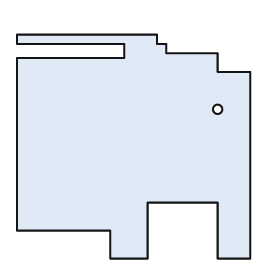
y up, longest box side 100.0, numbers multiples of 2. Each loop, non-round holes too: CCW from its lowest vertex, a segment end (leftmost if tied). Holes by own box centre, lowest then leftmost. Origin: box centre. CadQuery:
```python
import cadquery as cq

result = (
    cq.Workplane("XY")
    .moveTo(-10.0, -48.0)
    .lineTo(6.0, -48.0)
    .lineTo(6.0, -24.0)
    .lineTo(36.0, -24.0)
    .lineTo(36.0, -48.0)
    .lineTo(50.0, -48.0)
    .lineTo(50.0, 32.0)
    .lineTo(36.0, 32.0)
    .lineTo(36.0, 40.0)
    .lineTo(14.0, 40.0)
    .lineTo(14.0, 44.0)
    .lineTo(10.0, 44.0)
    .lineTo(10.0, 48.0)
    .lineTo(-50.0, 48.0)
    .lineTo(-50.0, 44.0)
    .lineTo(-4.0, 44.0)
    .lineTo(-4.0, 38.0)
    .lineTo(-50.0, 38.0)
    .lineTo(-50.0, -36.0)
    .lineTo(-10.0, -36.0)
    .close()
    .moveTo(36.0, 16.0)
    .circle(2.0)
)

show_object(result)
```